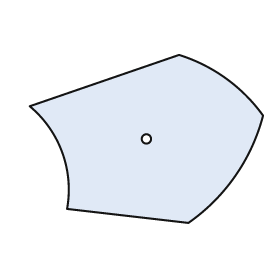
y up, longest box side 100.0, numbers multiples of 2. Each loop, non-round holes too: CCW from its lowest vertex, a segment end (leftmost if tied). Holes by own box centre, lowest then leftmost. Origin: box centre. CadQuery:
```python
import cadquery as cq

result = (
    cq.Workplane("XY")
    .moveTo(18.0, -36.0)
    .threePointArc((38.0, -16.0), (50.0, 10.0))
    .threePointArc((34.0, 26.0), (14.0, 36.0))
    .lineTo(-50.0, 14.0)
    .threePointArc((-36.0, -6.0), (-34.0, -30.0))
    .close()
    .moveTo(0.0, 0.0)
    .circle(2.0)
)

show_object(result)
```